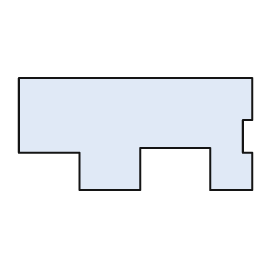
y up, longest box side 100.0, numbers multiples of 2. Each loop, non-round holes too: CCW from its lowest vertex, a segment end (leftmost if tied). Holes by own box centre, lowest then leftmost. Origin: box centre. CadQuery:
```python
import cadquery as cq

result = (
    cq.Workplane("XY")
    .moveTo(-24.0, -24.0)
    .lineTo(2.0, -24.0)
    .lineTo(2.0, -6.0)
    .lineTo(32.0, -6.0)
    .lineTo(32.0, -24.0)
    .lineTo(50.0, -24.0)
    .lineTo(50.0, -8.0)
    .lineTo(46.0, -8.0)
    .lineTo(46.0, 6.0)
    .lineTo(50.0, 6.0)
    .lineTo(50.0, 24.0)
    .lineTo(-50.0, 24.0)
    .lineTo(-50.0, -8.0)
    .lineTo(-24.0, -8.0)
    .close()
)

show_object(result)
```